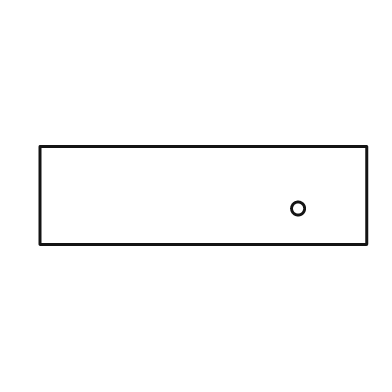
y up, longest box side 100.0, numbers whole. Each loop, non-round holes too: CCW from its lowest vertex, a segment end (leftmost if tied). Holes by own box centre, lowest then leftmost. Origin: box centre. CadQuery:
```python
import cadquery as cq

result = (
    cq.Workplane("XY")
    .moveTo(-50.0, -15.0)
    .lineTo(50.0, -15.0)
    .lineTo(50.0, 15.0)
    .lineTo(-50.0, 15.0)
    .close()
    .moveTo(29.0, -4.0)
    .circle(2.0)
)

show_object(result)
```